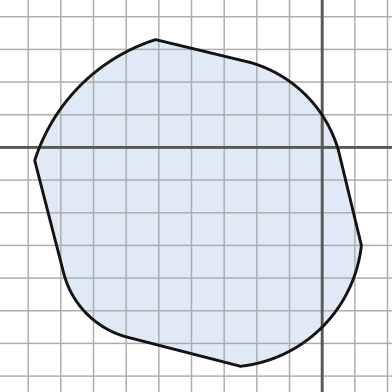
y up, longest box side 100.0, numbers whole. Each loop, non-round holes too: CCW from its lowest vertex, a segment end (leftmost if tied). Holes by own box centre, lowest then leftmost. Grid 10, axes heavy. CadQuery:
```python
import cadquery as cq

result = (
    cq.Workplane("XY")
    .moveTo(-25.0, -67.0)
    .threePointArc((0.0, -55.0), (12.0, -30.0))
    .lineTo(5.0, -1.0)
    .threePointArc((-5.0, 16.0), (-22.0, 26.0))
    .lineTo(-51.0, 33.0)
    .threePointArc((-74.0, 19.0), (-88.0, -4.0))
    .lineTo(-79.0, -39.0)
    .threePointArc((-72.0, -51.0), (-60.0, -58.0))
    .close()
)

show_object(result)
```